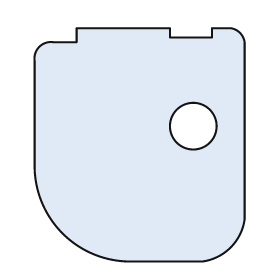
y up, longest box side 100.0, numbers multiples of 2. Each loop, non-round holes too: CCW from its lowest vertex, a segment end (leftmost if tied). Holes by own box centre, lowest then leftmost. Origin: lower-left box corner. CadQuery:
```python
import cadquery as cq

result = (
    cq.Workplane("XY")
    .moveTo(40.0, 0.0)
    .lineTo(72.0, 0.0)
    .threePointArc((84.0, 6.0), (90.0, 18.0))
    .lineTo(90.0, 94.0)
    .threePointArc((88.0, 98.0), (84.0, 100.0))
    .lineTo(76.0, 100.0)
    .lineTo(76.0, 96.0)
    .lineTo(58.0, 96.0)
    .lineTo(58.0, 100.0)
    .lineTo(18.0, 100.0)
    .lineTo(18.0, 94.0)
    .lineTo(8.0, 94.0)
    .threePointArc((2.0, 92.0), (0.0, 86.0))
    .lineTo(0.0, 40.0)
    .threePointArc((12.0, 12.0), (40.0, 0.0))
    .close()
    .moveTo(68.0, 58.0)
    .circle(10.0)
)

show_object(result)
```